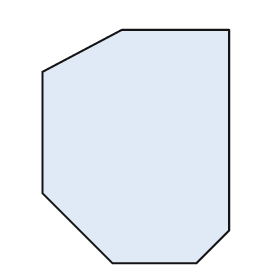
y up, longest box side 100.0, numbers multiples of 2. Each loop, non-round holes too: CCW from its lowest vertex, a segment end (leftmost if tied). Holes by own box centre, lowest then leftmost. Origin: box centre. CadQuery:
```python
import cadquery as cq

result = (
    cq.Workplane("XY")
    .moveTo(-10.0, -50.0)
    .lineTo(26.0, -50.0)
    .lineTo(40.0, -36.0)
    .lineTo(40.0, 50.0)
    .lineTo(-6.0, 50.0)
    .lineTo(-40.0, 32.0)
    .lineTo(-40.0, -20.0)
    .close()
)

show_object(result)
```